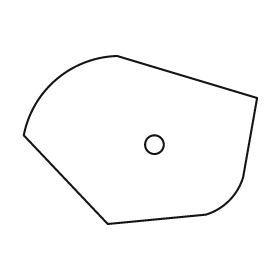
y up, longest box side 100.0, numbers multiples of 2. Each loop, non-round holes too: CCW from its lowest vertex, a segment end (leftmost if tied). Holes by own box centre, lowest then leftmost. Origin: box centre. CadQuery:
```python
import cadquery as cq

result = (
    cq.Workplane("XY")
    .moveTo(-14.0, -36.0)
    .lineTo(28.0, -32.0)
    .threePointArc((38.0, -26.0), (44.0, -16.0))
    .lineTo(50.0, 18.0)
    .lineTo(-10.0, 36.0)
    .threePointArc((-36.0, 26.0), (-50.0, 2.0))
    .close()
    .moveTo(6.0, -2.0)
    .circle(4.0)
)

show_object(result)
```